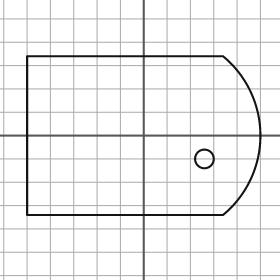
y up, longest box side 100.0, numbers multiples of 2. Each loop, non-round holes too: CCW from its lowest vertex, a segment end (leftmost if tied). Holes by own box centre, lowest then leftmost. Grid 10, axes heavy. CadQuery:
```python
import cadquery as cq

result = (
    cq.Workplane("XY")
    .moveTo(-50.0, -34.0)
    .lineTo(34.0, -34.0)
    .threePointArc((50.0, 0.0), (34.0, 34.0))
    .lineTo(-50.0, 34.0)
    .close()
    .moveTo(26.0, -10.0)
    .circle(4.0)
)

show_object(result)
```